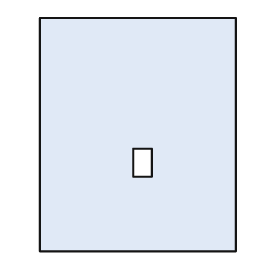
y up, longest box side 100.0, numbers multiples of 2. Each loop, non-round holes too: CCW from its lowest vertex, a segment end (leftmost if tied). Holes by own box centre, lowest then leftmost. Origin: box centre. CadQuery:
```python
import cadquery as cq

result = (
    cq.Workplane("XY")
    .moveTo(-42.0, -50.0)
    .lineTo(42.0, -50.0)
    .lineTo(42.0, 50.0)
    .lineTo(-42.0, 50.0)
    .close()
    .moveTo(-2.0, -18.0)
    .lineTo(6.0, -18.0)
    .lineTo(6.0, -6.0)
    .lineTo(-2.0, -6.0)
    .close()
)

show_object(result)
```